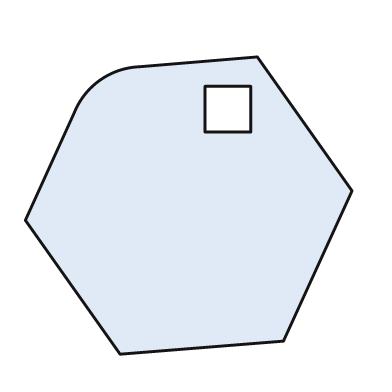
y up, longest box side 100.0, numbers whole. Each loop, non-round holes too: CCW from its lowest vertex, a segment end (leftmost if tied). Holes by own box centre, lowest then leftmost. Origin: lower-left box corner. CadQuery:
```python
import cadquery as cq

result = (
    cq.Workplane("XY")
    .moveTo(29.0, 0.0)
    .lineTo(79.0, 4.0)
    .lineTo(100.0, 50.0)
    .lineTo(71.0, 91.0)
    .lineTo(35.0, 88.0)
    .threePointArc((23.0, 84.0), (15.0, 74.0))
    .lineTo(0.0, 41.0)
    .close()
    .moveTo(55.0, 68.0)
    .lineTo(69.0, 68.0)
    .lineTo(69.0, 82.0)
    .lineTo(55.0, 82.0)
    .close()
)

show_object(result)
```